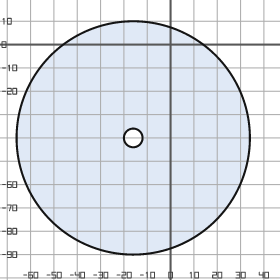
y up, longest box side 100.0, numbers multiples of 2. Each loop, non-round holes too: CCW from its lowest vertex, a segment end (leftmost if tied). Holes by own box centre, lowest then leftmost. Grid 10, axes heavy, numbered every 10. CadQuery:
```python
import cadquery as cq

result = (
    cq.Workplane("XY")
    .moveTo(-16.0, -40.0)
    .circle(50.0)
    .moveTo(-16.0, -40.0)
    .circle(4.0)
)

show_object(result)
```